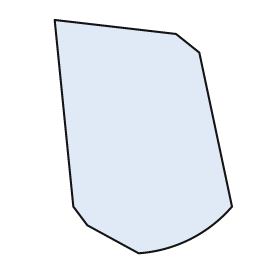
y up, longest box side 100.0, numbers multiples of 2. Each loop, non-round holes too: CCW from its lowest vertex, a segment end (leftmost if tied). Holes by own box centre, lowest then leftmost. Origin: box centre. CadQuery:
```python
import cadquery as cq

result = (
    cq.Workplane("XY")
    .moveTo(-2.0, -50.0)
    .threePointArc((20.0, -44.0), (38.0, -30.0))
    .lineTo(24.0, 36.0)
    .lineTo(14.0, 44.0)
    .lineTo(-38.0, 50.0)
    .lineTo(-30.0, -30.0)
    .lineTo(-24.0, -38.0)
    .close()
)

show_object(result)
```